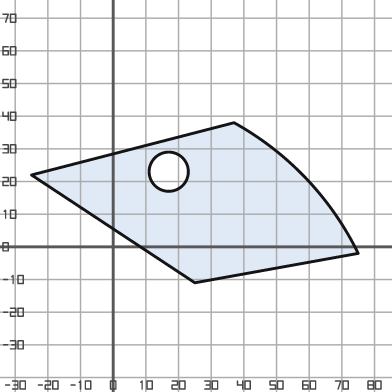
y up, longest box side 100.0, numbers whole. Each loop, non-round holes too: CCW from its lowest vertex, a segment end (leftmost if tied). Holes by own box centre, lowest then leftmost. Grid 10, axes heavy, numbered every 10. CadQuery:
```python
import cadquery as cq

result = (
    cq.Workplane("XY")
    .moveTo(25.0, -11.0)
    .lineTo(75.0, -2.0)
    .threePointArc((59.0, 21.0), (37.0, 38.0))
    .lineTo(-25.0, 22.0)
    .close()
    .moveTo(17.0, 23.0)
    .circle(6.0)
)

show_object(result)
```